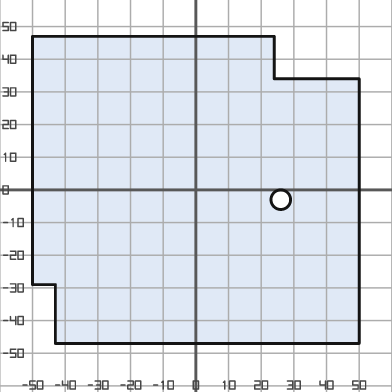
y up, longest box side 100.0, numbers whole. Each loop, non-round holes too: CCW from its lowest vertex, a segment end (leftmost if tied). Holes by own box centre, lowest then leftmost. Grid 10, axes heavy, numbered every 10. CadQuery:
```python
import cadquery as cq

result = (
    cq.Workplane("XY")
    .moveTo(-43.0, -47.0)
    .lineTo(50.0, -47.0)
    .lineTo(50.0, 34.0)
    .lineTo(24.0, 34.0)
    .lineTo(24.0, 47.0)
    .lineTo(-50.0, 47.0)
    .lineTo(-50.0, -29.0)
    .lineTo(-43.0, -29.0)
    .close()
    .moveTo(26.0, -3.0)
    .circle(3.0)
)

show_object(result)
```